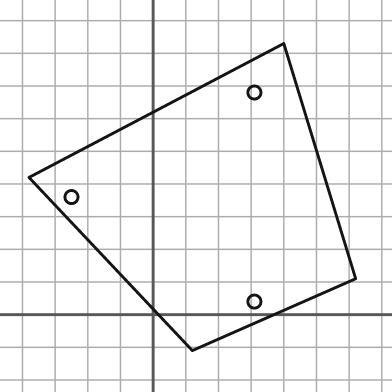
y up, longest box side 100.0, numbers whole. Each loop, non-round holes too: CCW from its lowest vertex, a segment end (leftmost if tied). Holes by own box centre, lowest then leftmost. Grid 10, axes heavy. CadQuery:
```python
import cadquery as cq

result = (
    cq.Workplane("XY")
    .moveTo(12.0, -11.0)
    .lineTo(62.0, 11.0)
    .lineTo(40.0, 83.0)
    .lineTo(-38.0, 42.0)
    .close()
    .moveTo(31.0, 4.0)
    .circle(2.0)
    .moveTo(-25.0, 36.0)
    .circle(2.0)
    .moveTo(31.0, 68.0)
    .circle(2.0)
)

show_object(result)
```